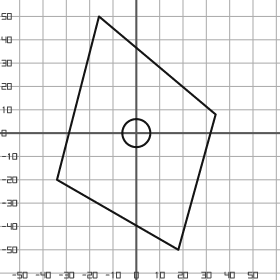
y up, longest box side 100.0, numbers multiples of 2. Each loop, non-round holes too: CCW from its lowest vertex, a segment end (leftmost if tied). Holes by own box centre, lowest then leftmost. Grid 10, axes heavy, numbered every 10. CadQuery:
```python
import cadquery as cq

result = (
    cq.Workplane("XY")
    .moveTo(18.0, -50.0)
    .lineTo(34.0, 8.0)
    .lineTo(-16.0, 50.0)
    .lineTo(-34.0, -20.0)
    .close()
    .moveTo(0.0, 0.0)
    .circle(6.0)
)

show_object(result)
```